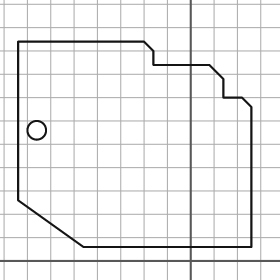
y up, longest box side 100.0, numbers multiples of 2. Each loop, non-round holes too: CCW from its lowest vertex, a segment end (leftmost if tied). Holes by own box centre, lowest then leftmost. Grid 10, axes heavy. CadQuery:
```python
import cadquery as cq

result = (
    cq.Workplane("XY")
    .moveTo(-46.0, 6.0)
    .lineTo(26.0, 6.0)
    .lineTo(26.0, 66.0)
    .lineTo(22.0, 70.0)
    .lineTo(14.0, 70.0)
    .lineTo(14.0, 78.0)
    .lineTo(8.0, 84.0)
    .lineTo(-16.0, 84.0)
    .lineTo(-16.0, 90.0)
    .lineTo(-20.0, 94.0)
    .lineTo(-74.0, 94.0)
    .lineTo(-74.0, 26.0)
    .close()
    .moveTo(-66.0, 56.0)
    .circle(4.0)
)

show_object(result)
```